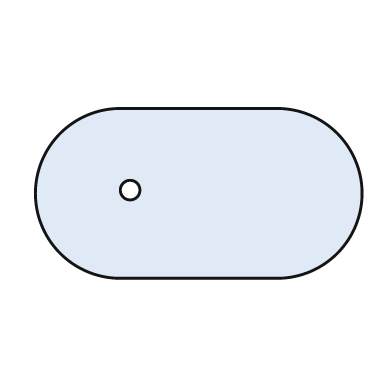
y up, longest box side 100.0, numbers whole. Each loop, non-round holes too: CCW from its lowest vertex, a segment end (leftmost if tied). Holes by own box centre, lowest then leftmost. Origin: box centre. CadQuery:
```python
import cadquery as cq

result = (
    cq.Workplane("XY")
    .moveTo(-24.0, -26.0)
    .lineTo(24.0, -26.0)
    .threePointArc((50.0, 0.0), (24.0, 26.0))
    .lineTo(-24.0, 26.0)
    .threePointArc((-50.0, 0.0), (-24.0, -26.0))
    .close()
    .moveTo(-21.0, 1.0)
    .circle(3.0)
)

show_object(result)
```